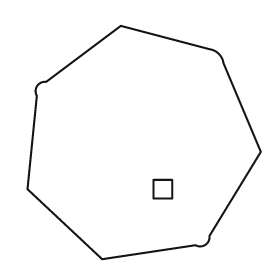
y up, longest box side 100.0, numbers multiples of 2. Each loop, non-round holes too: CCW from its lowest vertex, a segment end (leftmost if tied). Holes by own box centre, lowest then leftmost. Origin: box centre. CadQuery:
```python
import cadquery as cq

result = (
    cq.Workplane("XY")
    .moveTo(-18.0, -50.0)
    .lineTo(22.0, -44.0)
    .threePointArc((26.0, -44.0), (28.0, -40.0))
    .lineTo(50.0, -4.0)
    .lineTo(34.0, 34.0)
    .threePointArc((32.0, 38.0), (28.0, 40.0))
    .lineTo(-10.0, 50.0)
    .lineTo(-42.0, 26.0)
    .threePointArc((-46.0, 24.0), (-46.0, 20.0))
    .lineTo(-50.0, -20.0)
    .close()
    .moveTo(4.0, -24.0)
    .lineTo(12.0, -24.0)
    .lineTo(12.0, -16.0)
    .lineTo(4.0, -16.0)
    .close()
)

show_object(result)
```